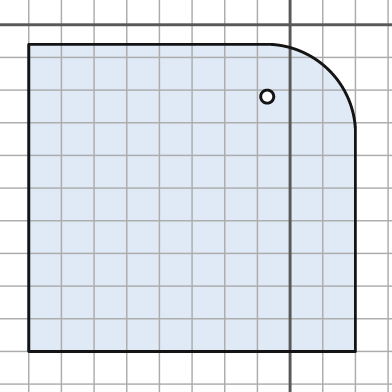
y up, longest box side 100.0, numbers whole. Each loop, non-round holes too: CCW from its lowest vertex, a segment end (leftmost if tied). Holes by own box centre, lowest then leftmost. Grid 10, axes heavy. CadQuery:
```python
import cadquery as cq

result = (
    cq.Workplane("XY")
    .moveTo(-80.0, -100.0)
    .lineTo(20.0, -100.0)
    .lineTo(20.0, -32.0)
    .threePointArc((12.0, -14.0), (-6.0, -6.0))
    .lineTo(-80.0, -6.0)
    .close()
    .moveTo(-7.0, -22.0)
    .circle(2.0)
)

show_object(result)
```